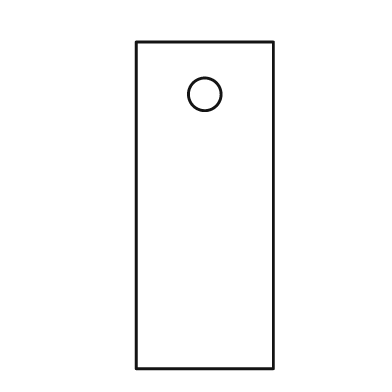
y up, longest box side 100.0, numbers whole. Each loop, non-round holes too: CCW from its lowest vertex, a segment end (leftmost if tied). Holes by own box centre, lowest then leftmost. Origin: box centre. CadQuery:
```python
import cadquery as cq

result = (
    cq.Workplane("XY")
    .moveTo(-21.0, -50.0)
    .lineTo(21.0, -50.0)
    .lineTo(21.0, 50.0)
    .lineTo(-21.0, 50.0)
    .close()
    .moveTo(0.0, 34.0)
    .circle(5.0)
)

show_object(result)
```